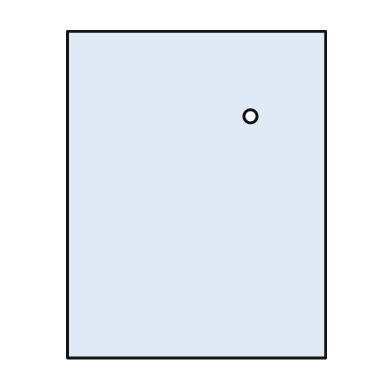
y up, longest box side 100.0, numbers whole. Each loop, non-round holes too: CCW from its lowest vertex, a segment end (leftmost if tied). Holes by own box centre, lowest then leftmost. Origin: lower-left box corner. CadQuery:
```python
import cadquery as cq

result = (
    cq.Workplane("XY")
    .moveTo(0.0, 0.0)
    .lineTo(79.0, 0.0)
    .lineTo(79.0, 100.0)
    .lineTo(0.0, 100.0)
    .close()
    .moveTo(56.0, 74.0)
    .circle(2.0)
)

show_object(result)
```